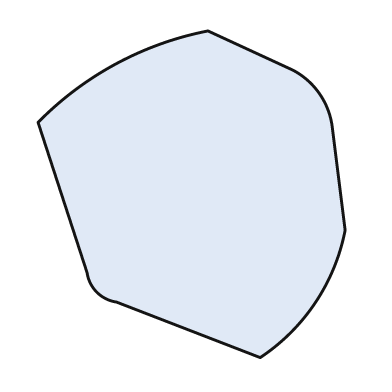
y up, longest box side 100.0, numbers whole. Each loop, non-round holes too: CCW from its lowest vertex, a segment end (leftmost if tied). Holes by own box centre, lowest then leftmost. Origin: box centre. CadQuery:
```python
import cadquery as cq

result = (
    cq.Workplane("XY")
    .moveTo(21.0, -50.0)
    .threePointArc((38.0, -33.0), (47.0, -11.0))
    .lineTo(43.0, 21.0)
    .threePointArc((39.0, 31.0), (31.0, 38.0))
    .lineTo(5.0, 50.0)
    .threePointArc((-23.0, 40.0), (-47.0, 22.0))
    .lineTo(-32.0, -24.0)
    .threePointArc((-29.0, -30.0), (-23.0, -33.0))
    .close()
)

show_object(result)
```